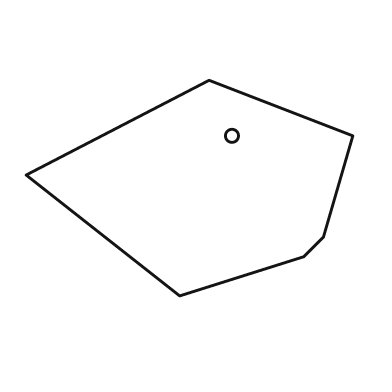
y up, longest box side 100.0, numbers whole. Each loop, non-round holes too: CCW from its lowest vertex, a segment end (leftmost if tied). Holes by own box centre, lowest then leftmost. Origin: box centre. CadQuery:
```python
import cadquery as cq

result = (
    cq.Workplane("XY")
    .moveTo(-3.0, -33.0)
    .lineTo(35.0, -21.0)
    .lineTo(41.0, -15.0)
    .lineTo(50.0, 16.0)
    .lineTo(6.0, 33.0)
    .lineTo(-50.0, 4.0)
    .close()
    .moveTo(13.0, 16.0)
    .circle(2.0)
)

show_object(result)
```